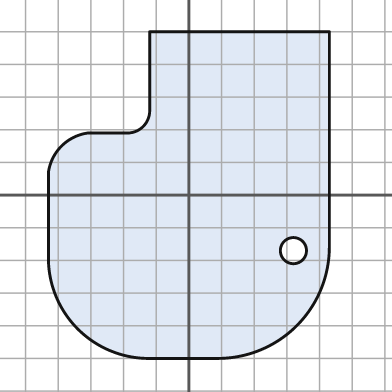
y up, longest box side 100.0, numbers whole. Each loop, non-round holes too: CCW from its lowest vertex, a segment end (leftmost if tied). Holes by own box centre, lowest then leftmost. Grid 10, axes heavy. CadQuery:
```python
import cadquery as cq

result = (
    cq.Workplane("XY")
    .moveTo(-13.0, -50.0)
    .lineTo(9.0, -50.0)
    .threePointArc((33.0, -40.0), (43.0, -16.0))
    .lineTo(43.0, 50.0)
    .lineTo(-12.0, 50.0)
    .lineTo(-12.0, 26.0)
    .threePointArc((-14.0, 21.0), (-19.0, 19.0))
    .lineTo(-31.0, 19.0)
    .threePointArc((-39.0, 15.0), (-43.0, 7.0))
    .lineTo(-43.0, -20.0)
    .threePointArc((-34.0, -41.0), (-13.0, -50.0))
    .close()
    .moveTo(32.0, -17.0)
    .circle(4.0)
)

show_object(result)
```